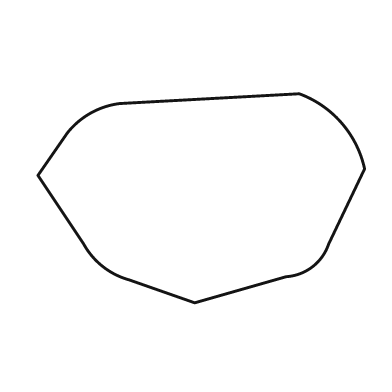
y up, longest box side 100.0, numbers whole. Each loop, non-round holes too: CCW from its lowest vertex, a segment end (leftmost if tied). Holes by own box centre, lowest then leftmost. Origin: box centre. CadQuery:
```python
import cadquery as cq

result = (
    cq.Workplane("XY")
    .moveTo(-2.0, -32.0)
    .lineTo(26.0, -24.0)
    .threePointArc((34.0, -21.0), (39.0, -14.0))
    .lineTo(50.0, 9.0)
    .threePointArc((43.0, 23.0), (30.0, 32.0))
    .lineTo(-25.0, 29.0)
    .threePointArc((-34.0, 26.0), (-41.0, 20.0))
    .lineTo(-50.0, 7.0)
    .lineTo(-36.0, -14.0)
    .threePointArc((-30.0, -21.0), (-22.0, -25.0))
    .close()
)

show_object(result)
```